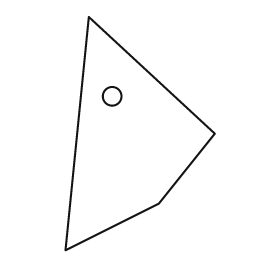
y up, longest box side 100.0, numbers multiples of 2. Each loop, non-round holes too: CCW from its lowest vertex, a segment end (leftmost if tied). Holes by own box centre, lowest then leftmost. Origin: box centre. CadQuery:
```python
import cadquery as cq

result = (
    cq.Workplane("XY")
    .moveTo(-32.0, -50.0)
    .lineTo(8.0, -30.0)
    .lineTo(32.0, 0.0)
    .lineTo(-22.0, 50.0)
    .close()
    .moveTo(-12.0, 16.0)
    .circle(4.0)
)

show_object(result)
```